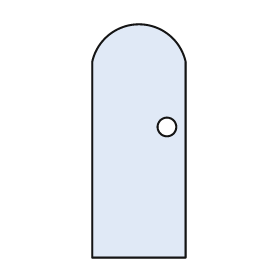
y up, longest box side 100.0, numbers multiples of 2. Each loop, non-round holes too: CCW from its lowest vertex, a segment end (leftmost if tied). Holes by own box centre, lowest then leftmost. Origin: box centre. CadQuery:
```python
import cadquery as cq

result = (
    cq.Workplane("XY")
    .moveTo(-20.0, -50.0)
    .lineTo(20.0, -50.0)
    .lineTo(20.0, 34.0)
    .threePointArc((0.0, 50.0), (-20.0, 34.0))
    .close()
    .moveTo(12.0, 6.0)
    .circle(4.0)
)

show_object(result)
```